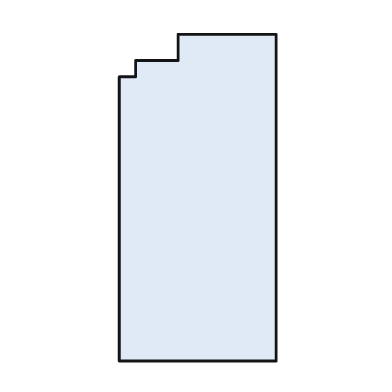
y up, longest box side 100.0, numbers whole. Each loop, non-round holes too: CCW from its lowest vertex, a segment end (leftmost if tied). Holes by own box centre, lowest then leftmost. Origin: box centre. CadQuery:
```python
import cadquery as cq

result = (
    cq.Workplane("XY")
    .moveTo(-24.0, -50.0)
    .lineTo(24.0, -50.0)
    .lineTo(24.0, 50.0)
    .lineTo(-6.0, 50.0)
    .lineTo(-6.0, 42.0)
    .lineTo(-19.0, 42.0)
    .lineTo(-19.0, 37.0)
    .lineTo(-24.0, 37.0)
    .close()
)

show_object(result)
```